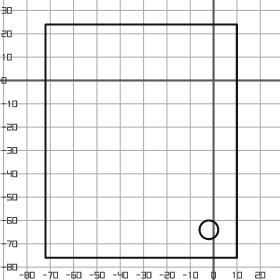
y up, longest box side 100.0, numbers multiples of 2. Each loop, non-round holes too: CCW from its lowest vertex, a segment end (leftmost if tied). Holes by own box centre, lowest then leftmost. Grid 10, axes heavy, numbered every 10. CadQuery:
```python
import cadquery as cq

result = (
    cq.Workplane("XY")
    .moveTo(-72.0, -76.0)
    .lineTo(10.0, -76.0)
    .lineTo(10.0, 24.0)
    .lineTo(-72.0, 24.0)
    .close()
    .moveTo(-2.0, -64.0)
    .circle(4.0)
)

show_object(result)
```